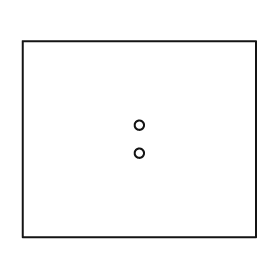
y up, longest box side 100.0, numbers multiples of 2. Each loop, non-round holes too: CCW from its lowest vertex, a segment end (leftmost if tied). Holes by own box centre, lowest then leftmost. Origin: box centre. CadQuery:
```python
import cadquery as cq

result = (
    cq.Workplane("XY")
    .moveTo(-50.0, -42.0)
    .lineTo(50.0, -42.0)
    .lineTo(50.0, 42.0)
    .lineTo(-50.0, 42.0)
    .close()
    .moveTo(0.0, -6.0)
    .circle(2.0)
    .moveTo(0.0, 6.0)
    .circle(2.0)
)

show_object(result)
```